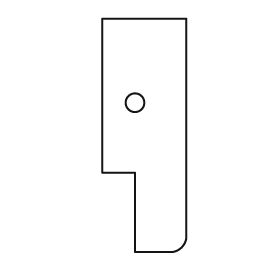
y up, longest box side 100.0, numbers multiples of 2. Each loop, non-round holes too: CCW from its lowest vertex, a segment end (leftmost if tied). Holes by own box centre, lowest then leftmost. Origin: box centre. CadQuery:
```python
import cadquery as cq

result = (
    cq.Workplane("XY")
    .moveTo(-4.0, -50.0)
    .lineTo(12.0, -50.0)
    .threePointArc((16.0, -48.0), (18.0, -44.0))
    .lineTo(18.0, 50.0)
    .lineTo(-18.0, 50.0)
    .lineTo(-18.0, -16.0)
    .lineTo(-4.0, -16.0)
    .close()
    .moveTo(-4.0, 14.0)
    .circle(4.0)
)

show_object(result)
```